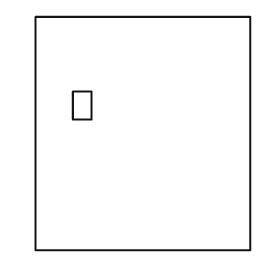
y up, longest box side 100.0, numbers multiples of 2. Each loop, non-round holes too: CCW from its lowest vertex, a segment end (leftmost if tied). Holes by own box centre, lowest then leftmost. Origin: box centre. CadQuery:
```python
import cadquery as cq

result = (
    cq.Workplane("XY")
    .moveTo(-46.0, -50.0)
    .lineTo(46.0, -50.0)
    .lineTo(46.0, 50.0)
    .lineTo(-46.0, 50.0)
    .close()
    .moveTo(-30.0, 6.0)
    .lineTo(-22.0, 6.0)
    .lineTo(-22.0, 18.0)
    .lineTo(-30.0, 18.0)
    .close()
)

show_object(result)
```